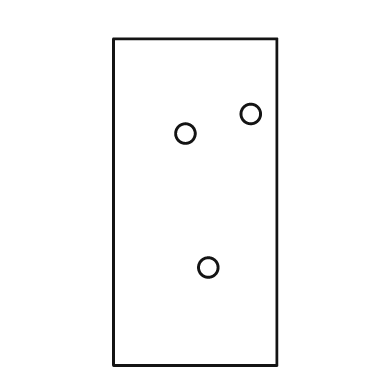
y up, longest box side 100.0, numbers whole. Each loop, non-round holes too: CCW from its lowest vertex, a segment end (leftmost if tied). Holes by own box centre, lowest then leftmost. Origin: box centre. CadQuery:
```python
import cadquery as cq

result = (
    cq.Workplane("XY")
    .moveTo(-25.0, -50.0)
    .lineTo(25.0, -50.0)
    .lineTo(25.0, 50.0)
    .lineTo(-25.0, 50.0)
    .close()
    .moveTo(4.0, -20.0)
    .circle(3.0)
    .moveTo(-3.0, 21.0)
    .circle(3.0)
    .moveTo(17.0, 27.0)
    .circle(3.0)
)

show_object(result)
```